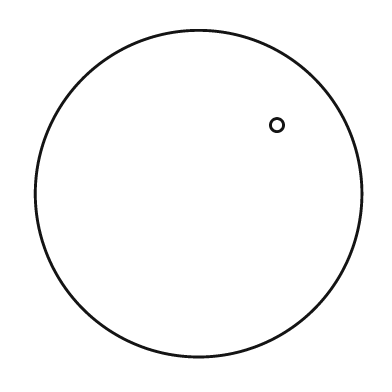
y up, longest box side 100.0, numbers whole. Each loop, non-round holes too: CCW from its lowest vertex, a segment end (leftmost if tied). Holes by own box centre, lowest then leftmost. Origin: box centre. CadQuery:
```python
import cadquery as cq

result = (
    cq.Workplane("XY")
    .moveTo(0.0, 0.0)
    .circle(50.0)
    .moveTo(24.0, 21.0)
    .circle(2.0)
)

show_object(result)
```